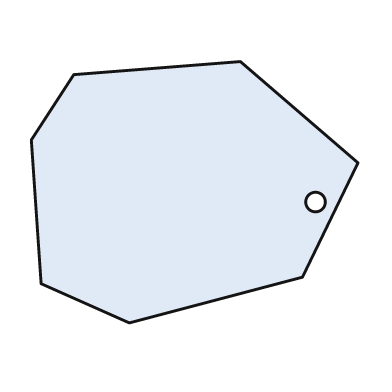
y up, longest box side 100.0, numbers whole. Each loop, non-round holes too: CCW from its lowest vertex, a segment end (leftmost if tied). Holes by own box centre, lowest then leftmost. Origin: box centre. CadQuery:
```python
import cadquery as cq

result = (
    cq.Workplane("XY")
    .moveTo(-20.0, -40.0)
    .lineTo(33.0, -26.0)
    .lineTo(50.0, 9.0)
    .lineTo(14.0, 40.0)
    .lineTo(-37.0, 36.0)
    .lineTo(-50.0, 16.0)
    .lineTo(-47.0, -28.0)
    .close()
    .moveTo(37.0, -3.0)
    .circle(3.0)
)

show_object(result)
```